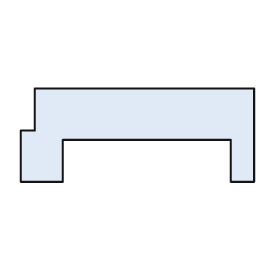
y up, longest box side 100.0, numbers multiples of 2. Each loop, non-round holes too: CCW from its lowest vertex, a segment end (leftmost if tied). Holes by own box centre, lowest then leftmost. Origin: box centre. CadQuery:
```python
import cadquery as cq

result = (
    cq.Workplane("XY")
    .moveTo(-50.0, -20.0)
    .lineTo(-32.0, -20.0)
    .lineTo(-32.0, -2.0)
    .lineTo(40.0, -2.0)
    .lineTo(40.0, -20.0)
    .lineTo(50.0, -20.0)
    .lineTo(50.0, 20.0)
    .lineTo(-44.0, 20.0)
    .lineTo(-44.0, 2.0)
    .lineTo(-50.0, 2.0)
    .close()
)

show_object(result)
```